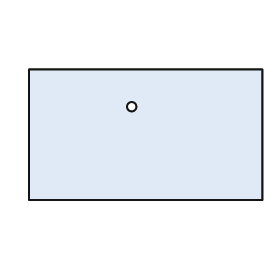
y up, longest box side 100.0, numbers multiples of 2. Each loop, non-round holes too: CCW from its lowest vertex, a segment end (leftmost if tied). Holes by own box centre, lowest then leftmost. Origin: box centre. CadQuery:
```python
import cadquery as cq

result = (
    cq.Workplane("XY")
    .moveTo(-50.0, -28.0)
    .lineTo(50.0, -28.0)
    .lineTo(50.0, 28.0)
    .lineTo(-50.0, 28.0)
    .close()
    .moveTo(-6.0, 12.0)
    .circle(2.0)
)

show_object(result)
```